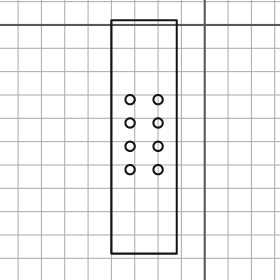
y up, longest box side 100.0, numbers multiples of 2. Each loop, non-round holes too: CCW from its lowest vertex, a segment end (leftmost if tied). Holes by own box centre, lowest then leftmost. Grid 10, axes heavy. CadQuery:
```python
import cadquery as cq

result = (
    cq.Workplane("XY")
    .moveTo(-40.0, -98.0)
    .lineTo(-12.0, -98.0)
    .lineTo(-12.0, 2.0)
    .lineTo(-40.0, 2.0)
    .close()
    .moveTo(-32.0, -62.0)
    .circle(2.0)
    .moveTo(-20.0, -62.0)
    .circle(2.0)
    .moveTo(-32.0, -52.0)
    .circle(2.0)
    .moveTo(-20.0, -52.0)
    .circle(2.0)
    .moveTo(-32.0, -42.0)
    .circle(2.0)
    .moveTo(-20.0, -42.0)
    .circle(2.0)
    .moveTo(-32.0, -32.0)
    .circle(2.0)
    .moveTo(-20.0, -32.0)
    .circle(2.0)
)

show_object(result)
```